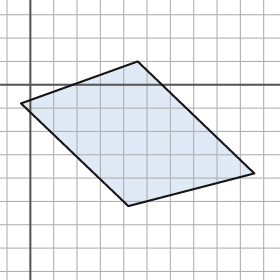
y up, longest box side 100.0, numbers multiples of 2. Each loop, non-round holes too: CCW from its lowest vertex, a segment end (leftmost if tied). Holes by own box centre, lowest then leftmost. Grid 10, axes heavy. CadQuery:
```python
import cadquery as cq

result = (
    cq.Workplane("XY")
    .moveTo(42.0, -52.0)
    .lineTo(96.0, -38.0)
    .lineTo(46.0, 10.0)
    .lineTo(-4.0, -8.0)
    .close()
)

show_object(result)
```